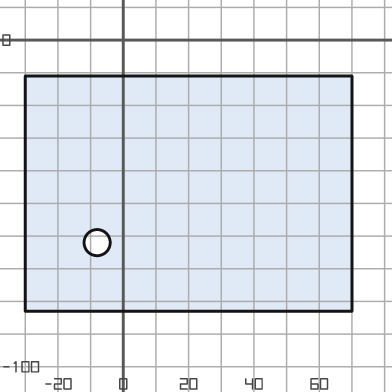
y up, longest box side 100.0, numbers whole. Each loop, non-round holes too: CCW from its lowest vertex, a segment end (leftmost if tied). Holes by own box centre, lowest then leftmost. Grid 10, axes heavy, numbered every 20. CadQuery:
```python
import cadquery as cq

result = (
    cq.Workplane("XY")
    .moveTo(-30.0, -83.0)
    .lineTo(70.0, -83.0)
    .lineTo(70.0, -11.0)
    .lineTo(-30.0, -11.0)
    .close()
    .moveTo(-8.0, -62.0)
    .circle(4.0)
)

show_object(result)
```